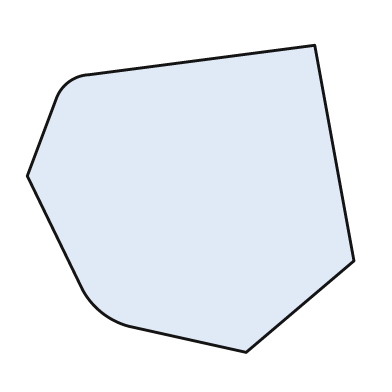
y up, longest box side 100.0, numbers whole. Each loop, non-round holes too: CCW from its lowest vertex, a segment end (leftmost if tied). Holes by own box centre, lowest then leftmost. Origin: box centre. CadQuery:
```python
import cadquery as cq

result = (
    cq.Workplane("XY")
    .moveTo(17.0, -47.0)
    .lineTo(50.0, -19.0)
    .lineTo(38.0, 47.0)
    .lineTo(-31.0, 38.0)
    .threePointArc((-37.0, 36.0), (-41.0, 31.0))
    .lineTo(-50.0, 7.0)
    .lineTo(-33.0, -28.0)
    .threePointArc((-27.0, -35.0), (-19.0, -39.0))
    .close()
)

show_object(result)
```